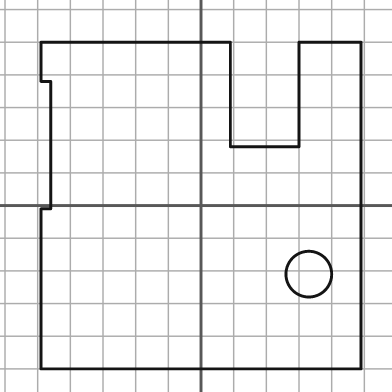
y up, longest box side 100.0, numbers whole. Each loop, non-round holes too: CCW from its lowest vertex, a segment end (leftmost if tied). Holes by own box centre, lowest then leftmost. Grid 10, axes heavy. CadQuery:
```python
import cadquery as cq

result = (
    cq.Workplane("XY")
    .moveTo(-49.0, -50.0)
    .lineTo(49.0, -50.0)
    .lineTo(49.0, 50.0)
    .lineTo(30.0, 50.0)
    .lineTo(30.0, 18.0)
    .lineTo(9.0, 18.0)
    .lineTo(9.0, 50.0)
    .lineTo(-49.0, 50.0)
    .lineTo(-49.0, 38.0)
    .lineTo(-46.0, 38.0)
    .lineTo(-46.0, -1.0)
    .lineTo(-49.0, -1.0)
    .close()
    .moveTo(33.0, -21.0)
    .circle(7.0)
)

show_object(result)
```